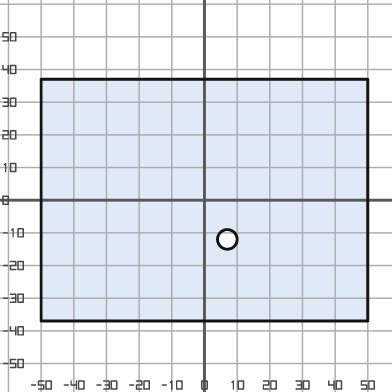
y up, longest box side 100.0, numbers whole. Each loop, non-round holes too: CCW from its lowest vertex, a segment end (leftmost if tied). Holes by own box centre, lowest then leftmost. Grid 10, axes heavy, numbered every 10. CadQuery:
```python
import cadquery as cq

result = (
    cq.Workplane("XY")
    .moveTo(-50.0, -37.0)
    .lineTo(50.0, -37.0)
    .lineTo(50.0, 37.0)
    .lineTo(-50.0, 37.0)
    .close()
    .moveTo(7.0, -12.0)
    .circle(3.0)
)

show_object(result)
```